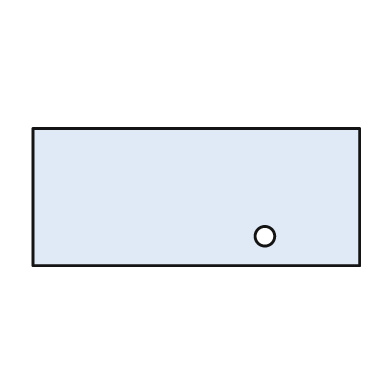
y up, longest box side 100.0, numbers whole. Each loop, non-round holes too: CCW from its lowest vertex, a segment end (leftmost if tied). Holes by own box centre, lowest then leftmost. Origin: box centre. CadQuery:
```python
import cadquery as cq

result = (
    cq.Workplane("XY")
    .moveTo(-50.0, -21.0)
    .lineTo(50.0, -21.0)
    .lineTo(50.0, 21.0)
    .lineTo(-50.0, 21.0)
    .close()
    .moveTo(21.0, -12.0)
    .circle(3.0)
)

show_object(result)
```